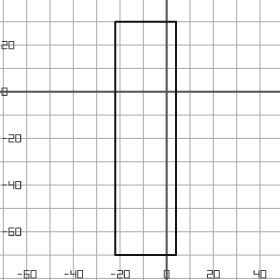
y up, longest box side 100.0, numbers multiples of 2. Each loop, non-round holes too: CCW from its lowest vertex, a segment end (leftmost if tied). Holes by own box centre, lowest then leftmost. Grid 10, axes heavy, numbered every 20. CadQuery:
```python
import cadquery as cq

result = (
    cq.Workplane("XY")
    .moveTo(-22.0, -70.0)
    .lineTo(4.0, -70.0)
    .lineTo(4.0, 30.0)
    .lineTo(-22.0, 30.0)
    .close()
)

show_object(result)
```